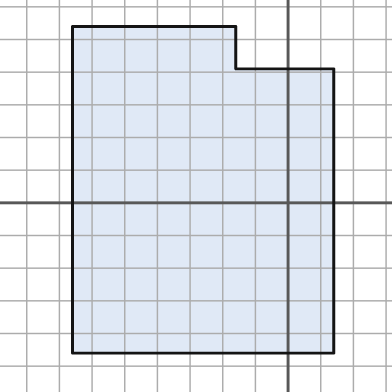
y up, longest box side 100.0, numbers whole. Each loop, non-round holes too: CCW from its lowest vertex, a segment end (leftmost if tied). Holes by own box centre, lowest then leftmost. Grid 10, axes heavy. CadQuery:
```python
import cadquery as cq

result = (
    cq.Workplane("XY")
    .moveTo(-66.0, -46.0)
    .lineTo(14.0, -46.0)
    .lineTo(14.0, 41.0)
    .lineTo(-16.0, 41.0)
    .lineTo(-16.0, 54.0)
    .lineTo(-66.0, 54.0)
    .close()
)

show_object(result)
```